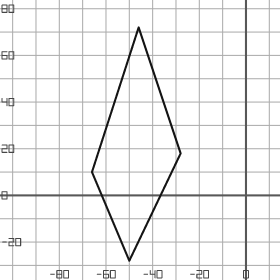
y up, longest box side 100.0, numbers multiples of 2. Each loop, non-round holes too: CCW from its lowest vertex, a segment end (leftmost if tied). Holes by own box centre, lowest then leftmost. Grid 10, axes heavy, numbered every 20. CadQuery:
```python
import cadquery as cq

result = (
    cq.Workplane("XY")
    .moveTo(-50.0, -28.0)
    .lineTo(-28.0, 18.0)
    .lineTo(-46.0, 72.0)
    .lineTo(-66.0, 10.0)
    .close()
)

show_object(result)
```